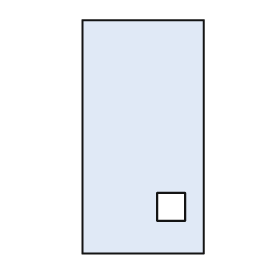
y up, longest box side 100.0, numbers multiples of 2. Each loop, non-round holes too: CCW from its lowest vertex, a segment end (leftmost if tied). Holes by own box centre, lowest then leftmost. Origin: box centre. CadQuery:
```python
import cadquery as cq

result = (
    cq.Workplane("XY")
    .moveTo(-26.0, -50.0)
    .lineTo(26.0, -50.0)
    .lineTo(26.0, 50.0)
    .lineTo(-26.0, 50.0)
    .close()
    .moveTo(6.0, -36.0)
    .lineTo(18.0, -36.0)
    .lineTo(18.0, -24.0)
    .lineTo(6.0, -24.0)
    .close()
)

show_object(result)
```